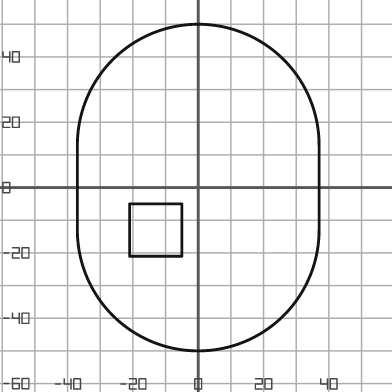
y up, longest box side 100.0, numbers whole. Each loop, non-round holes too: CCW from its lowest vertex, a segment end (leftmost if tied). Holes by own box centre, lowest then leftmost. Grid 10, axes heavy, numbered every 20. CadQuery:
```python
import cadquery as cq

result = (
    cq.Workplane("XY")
    .moveTo(-37.0, -13.0)
    .threePointArc((0.0, -50.0), (37.0, -13.0))
    .lineTo(37.0, 13.0)
    .threePointArc((0.0, 50.0), (-37.0, 13.0))
    .close()
    .moveTo(-21.0, -21.0)
    .lineTo(-5.0, -21.0)
    .lineTo(-5.0, -5.0)
    .lineTo(-21.0, -5.0)
    .close()
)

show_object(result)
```